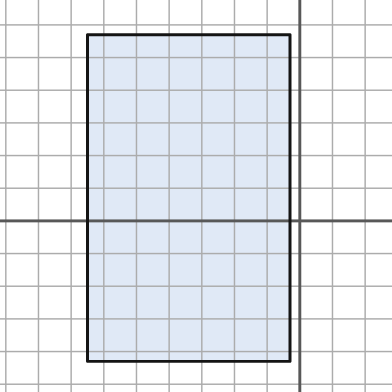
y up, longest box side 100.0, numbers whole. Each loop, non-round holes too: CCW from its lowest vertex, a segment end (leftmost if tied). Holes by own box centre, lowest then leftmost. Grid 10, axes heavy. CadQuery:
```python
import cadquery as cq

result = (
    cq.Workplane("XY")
    .moveTo(-65.0, -43.0)
    .lineTo(-3.0, -43.0)
    .lineTo(-3.0, 57.0)
    .lineTo(-65.0, 57.0)
    .close()
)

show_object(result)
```